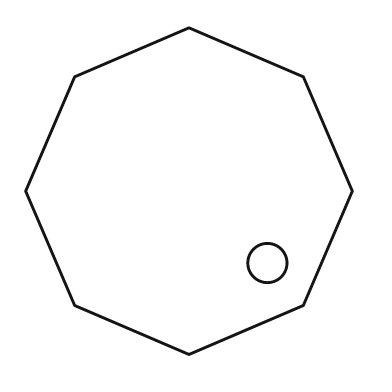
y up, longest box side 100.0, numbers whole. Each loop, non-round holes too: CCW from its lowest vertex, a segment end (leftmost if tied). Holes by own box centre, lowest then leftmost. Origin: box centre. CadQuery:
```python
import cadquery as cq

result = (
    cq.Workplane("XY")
    .moveTo(0.0, -50.0)
    .lineTo(35.0, -35.0)
    .lineTo(50.0, 0.0)
    .lineTo(35.0, 35.0)
    .lineTo(0.0, 50.0)
    .lineTo(-35.0, 35.0)
    .lineTo(-50.0, 0.0)
    .lineTo(-35.0, -35.0)
    .close()
    .moveTo(24.0, -22.0)
    .circle(6.0)
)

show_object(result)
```